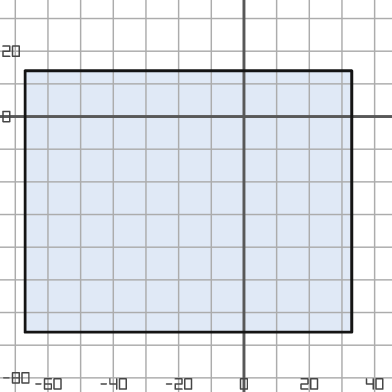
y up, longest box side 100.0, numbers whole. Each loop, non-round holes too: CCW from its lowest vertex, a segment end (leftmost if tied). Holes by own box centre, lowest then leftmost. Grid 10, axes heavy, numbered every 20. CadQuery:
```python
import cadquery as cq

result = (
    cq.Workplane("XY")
    .moveTo(-67.0, -66.0)
    .lineTo(33.0, -66.0)
    .lineTo(33.0, 14.0)
    .lineTo(-67.0, 14.0)
    .close()
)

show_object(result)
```